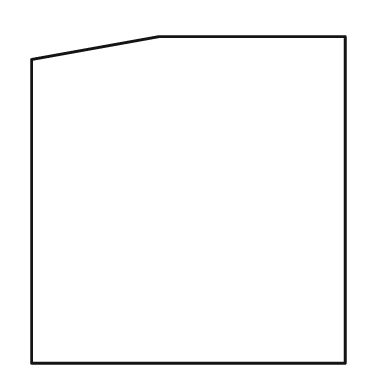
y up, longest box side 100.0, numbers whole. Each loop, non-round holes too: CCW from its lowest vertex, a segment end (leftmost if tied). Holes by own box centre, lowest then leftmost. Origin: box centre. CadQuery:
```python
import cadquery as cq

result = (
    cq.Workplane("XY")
    .moveTo(-48.0, -50.0)
    .lineTo(48.0, -50.0)
    .lineTo(48.0, 50.0)
    .lineTo(-9.0, 50.0)
    .lineTo(-48.0, 43.0)
    .close()
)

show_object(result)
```